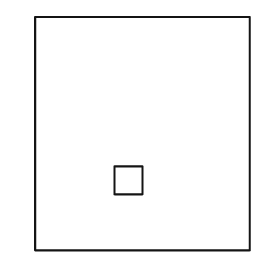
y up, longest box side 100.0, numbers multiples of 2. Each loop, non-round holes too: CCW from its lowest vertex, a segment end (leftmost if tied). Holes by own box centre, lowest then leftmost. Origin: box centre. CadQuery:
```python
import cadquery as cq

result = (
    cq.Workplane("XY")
    .moveTo(-46.0, -50.0)
    .lineTo(46.0, -50.0)
    .lineTo(46.0, 50.0)
    .lineTo(-46.0, 50.0)
    .close()
    .moveTo(-12.0, -26.0)
    .lineTo(0.0, -26.0)
    .lineTo(0.0, -14.0)
    .lineTo(-12.0, -14.0)
    .close()
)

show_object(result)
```